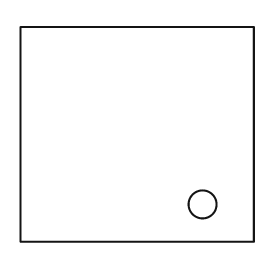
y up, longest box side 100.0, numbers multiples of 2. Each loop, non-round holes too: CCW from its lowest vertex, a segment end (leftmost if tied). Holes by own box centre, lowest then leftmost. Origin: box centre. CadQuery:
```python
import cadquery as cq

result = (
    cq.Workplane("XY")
    .moveTo(-50.0, -46.0)
    .lineTo(50.0, -46.0)
    .lineTo(50.0, 46.0)
    .lineTo(-50.0, 46.0)
    .close()
    .moveTo(28.0, -30.0)
    .circle(6.0)
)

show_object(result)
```